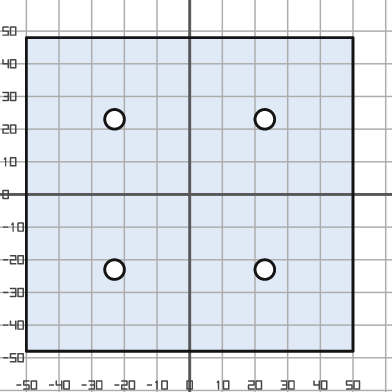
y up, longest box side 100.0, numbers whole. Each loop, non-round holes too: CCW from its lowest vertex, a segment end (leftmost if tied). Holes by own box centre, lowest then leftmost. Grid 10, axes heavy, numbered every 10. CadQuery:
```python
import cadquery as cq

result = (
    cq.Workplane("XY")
    .moveTo(-50.0, -48.0)
    .lineTo(50.0, -48.0)
    .lineTo(50.0, 48.0)
    .lineTo(-50.0, 48.0)
    .close()
    .moveTo(-23.0, -23.0)
    .circle(3.0)
    .moveTo(23.0, -23.0)
    .circle(3.0)
    .moveTo(-23.0, 23.0)
    .circle(3.0)
    .moveTo(23.0, 23.0)
    .circle(3.0)
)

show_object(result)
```